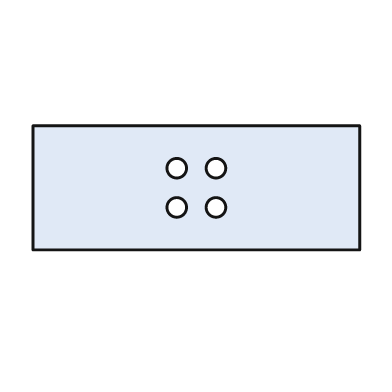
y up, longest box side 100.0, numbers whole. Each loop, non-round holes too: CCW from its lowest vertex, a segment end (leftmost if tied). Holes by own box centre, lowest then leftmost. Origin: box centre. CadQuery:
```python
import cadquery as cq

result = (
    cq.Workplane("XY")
    .moveTo(-50.0, -19.0)
    .lineTo(50.0, -19.0)
    .lineTo(50.0, 19.0)
    .lineTo(-50.0, 19.0)
    .close()
    .moveTo(-6.0, -6.0)
    .circle(3.0)
    .moveTo(6.0, -6.0)
    .circle(3.0)
    .moveTo(-6.0, 6.0)
    .circle(3.0)
    .moveTo(6.0, 6.0)
    .circle(3.0)
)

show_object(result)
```